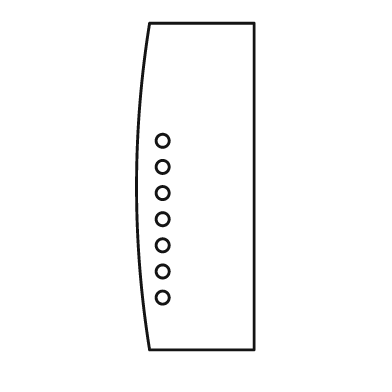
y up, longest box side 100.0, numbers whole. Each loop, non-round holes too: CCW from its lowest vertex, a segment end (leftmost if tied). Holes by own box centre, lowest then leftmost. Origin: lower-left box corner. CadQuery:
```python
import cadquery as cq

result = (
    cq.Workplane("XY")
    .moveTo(4.0, 0.0)
    .lineTo(36.0, 0.0)
    .lineTo(36.0, 100.0)
    .lineTo(4.0, 100.0)
    .threePointArc((0.0, 50.0), (4.0, 0.0))
    .close()
    .moveTo(8.0, 16.0)
    .circle(2.0)
    .moveTo(8.0, 24.0)
    .circle(2.0)
    .moveTo(8.0, 32.0)
    .circle(2.0)
    .moveTo(8.0, 40.0)
    .circle(2.0)
    .moveTo(8.0, 48.0)
    .circle(2.0)
    .moveTo(8.0, 56.0)
    .circle(2.0)
    .moveTo(8.0, 64.0)
    .circle(2.0)
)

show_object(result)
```